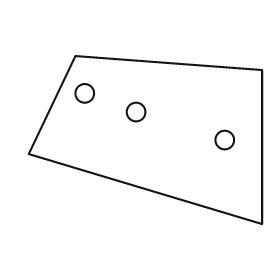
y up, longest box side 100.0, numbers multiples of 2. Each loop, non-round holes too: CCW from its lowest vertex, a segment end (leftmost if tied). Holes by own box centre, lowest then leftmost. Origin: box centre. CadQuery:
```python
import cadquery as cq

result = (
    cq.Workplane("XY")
    .moveTo(50.0, -36.0)
    .lineTo(50.0, 30.0)
    .lineTo(-30.0, 36.0)
    .lineTo(-50.0, -6.0)
    .close()
    .moveTo(34.0, 0.0)
    .circle(4.0)
    .moveTo(-4.0, 12.0)
    .circle(4.0)
    .moveTo(-26.0, 20.0)
    .circle(4.0)
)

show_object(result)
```